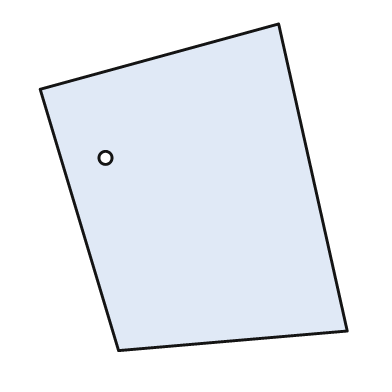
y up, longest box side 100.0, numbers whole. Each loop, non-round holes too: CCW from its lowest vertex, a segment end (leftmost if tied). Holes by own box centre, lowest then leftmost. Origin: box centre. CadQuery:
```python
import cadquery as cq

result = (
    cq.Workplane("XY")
    .moveTo(-23.0, -50.0)
    .lineTo(47.0, -44.0)
    .lineTo(26.0, 50.0)
    .lineTo(-47.0, 30.0)
    .close()
    .moveTo(-27.0, 9.0)
    .circle(2.0)
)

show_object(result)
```